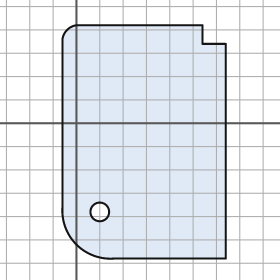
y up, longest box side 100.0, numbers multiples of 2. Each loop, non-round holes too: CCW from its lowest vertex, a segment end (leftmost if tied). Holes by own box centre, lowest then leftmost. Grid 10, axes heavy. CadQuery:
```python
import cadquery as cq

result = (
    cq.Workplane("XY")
    .moveTo(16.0, -58.0)
    .lineTo(64.0, -58.0)
    .lineTo(64.0, 34.0)
    .lineTo(54.0, 34.0)
    .lineTo(54.0, 42.0)
    .lineTo(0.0, 42.0)
    .threePointArc((-4.0, 40.0), (-6.0, 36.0))
    .lineTo(-6.0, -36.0)
    .threePointArc((0.0, -52.0), (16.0, -58.0))
    .close()
    .moveTo(10.0, -38.0)
    .circle(4.0)
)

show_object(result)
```